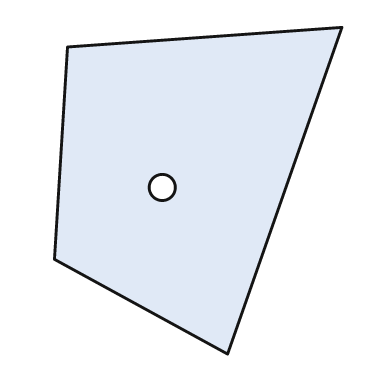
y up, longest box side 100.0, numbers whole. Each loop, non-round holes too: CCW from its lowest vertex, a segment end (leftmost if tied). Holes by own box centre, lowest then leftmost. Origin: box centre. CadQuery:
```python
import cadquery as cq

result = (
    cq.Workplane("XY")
    .moveTo(9.0, -50.0)
    .lineTo(44.0, 50.0)
    .lineTo(-40.0, 44.0)
    .lineTo(-44.0, -21.0)
    .close()
    .moveTo(-11.0, 1.0)
    .circle(4.0)
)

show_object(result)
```